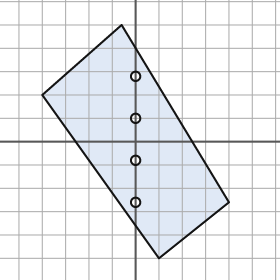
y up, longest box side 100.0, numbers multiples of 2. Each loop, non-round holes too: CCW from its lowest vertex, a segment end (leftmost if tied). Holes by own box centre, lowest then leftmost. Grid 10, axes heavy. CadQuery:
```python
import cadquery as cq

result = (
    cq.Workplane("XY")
    .moveTo(10.0, -50.0)
    .lineTo(40.0, -26.0)
    .lineTo(-6.0, 50.0)
    .lineTo(-40.0, 20.0)
    .close()
    .moveTo(0.0, -26.0)
    .circle(2.0)
    .moveTo(0.0, -8.0)
    .circle(2.0)
    .moveTo(0.0, 10.0)
    .circle(2.0)
    .moveTo(0.0, 28.0)
    .circle(2.0)
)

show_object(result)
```